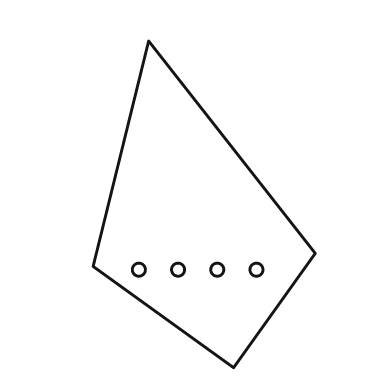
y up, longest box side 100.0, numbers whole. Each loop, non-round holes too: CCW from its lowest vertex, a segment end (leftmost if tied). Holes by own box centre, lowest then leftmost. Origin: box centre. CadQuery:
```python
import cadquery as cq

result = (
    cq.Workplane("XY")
    .moveTo(9.0, -50.0)
    .lineTo(34.0, -15.0)
    .lineTo(-17.0, 50.0)
    .lineTo(-34.0, -19.0)
    .close()
    .moveTo(-20.0, -20.0)
    .circle(2.0)
    .moveTo(-8.0, -20.0)
    .circle(2.0)
    .moveTo(4.0, -20.0)
    .circle(2.0)
    .moveTo(16.0, -20.0)
    .circle(2.0)
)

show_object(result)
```